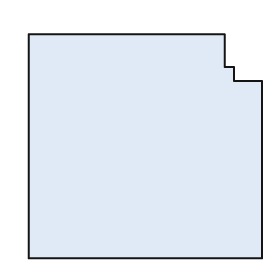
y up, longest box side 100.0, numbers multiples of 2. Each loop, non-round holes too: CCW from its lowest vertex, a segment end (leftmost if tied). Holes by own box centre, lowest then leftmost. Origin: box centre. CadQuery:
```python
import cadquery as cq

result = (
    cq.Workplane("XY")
    .moveTo(-50.0, -48.0)
    .lineTo(50.0, -48.0)
    .lineTo(50.0, 28.0)
    .lineTo(38.0, 28.0)
    .lineTo(38.0, 34.0)
    .lineTo(34.0, 34.0)
    .lineTo(34.0, 48.0)
    .lineTo(-50.0, 48.0)
    .close()
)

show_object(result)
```